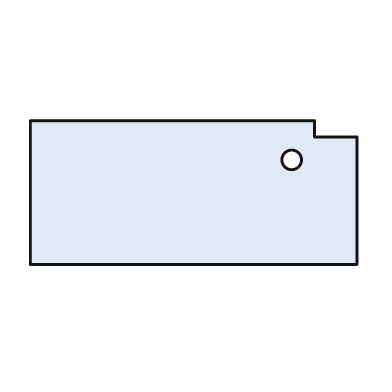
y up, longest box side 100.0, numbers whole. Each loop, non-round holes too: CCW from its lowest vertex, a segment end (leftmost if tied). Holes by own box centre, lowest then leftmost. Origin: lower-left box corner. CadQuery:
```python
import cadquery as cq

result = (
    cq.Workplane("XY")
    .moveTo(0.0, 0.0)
    .lineTo(100.0, 0.0)
    .lineTo(100.0, 39.0)
    .lineTo(87.0, 39.0)
    .lineTo(87.0, 44.0)
    .lineTo(0.0, 44.0)
    .close()
    .moveTo(80.0, 32.0)
    .circle(3.0)
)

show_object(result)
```